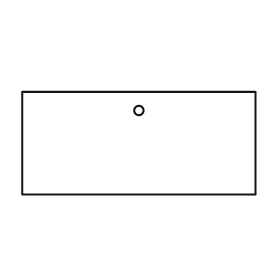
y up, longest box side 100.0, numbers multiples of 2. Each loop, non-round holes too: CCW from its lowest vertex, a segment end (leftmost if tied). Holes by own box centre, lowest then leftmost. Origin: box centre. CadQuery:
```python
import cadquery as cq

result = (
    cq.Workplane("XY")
    .moveTo(-50.0, -22.0)
    .lineTo(50.0, -22.0)
    .lineTo(50.0, 22.0)
    .lineTo(-50.0, 22.0)
    .close()
    .moveTo(0.0, 14.0)
    .circle(2.0)
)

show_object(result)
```